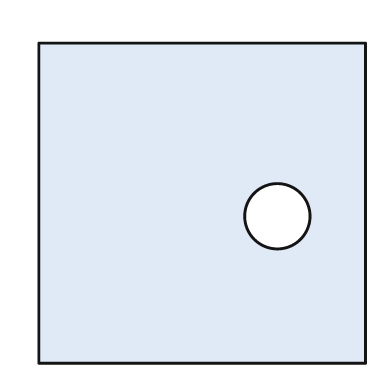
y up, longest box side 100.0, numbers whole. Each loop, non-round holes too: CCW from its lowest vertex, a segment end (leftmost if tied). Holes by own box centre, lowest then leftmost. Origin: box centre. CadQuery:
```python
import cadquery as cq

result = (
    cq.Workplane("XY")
    .moveTo(-50.0, -49.0)
    .lineTo(50.0, -49.0)
    .lineTo(50.0, 49.0)
    .lineTo(-50.0, 49.0)
    .close()
    .moveTo(23.0, -4.0)
    .circle(10.0)
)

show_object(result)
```